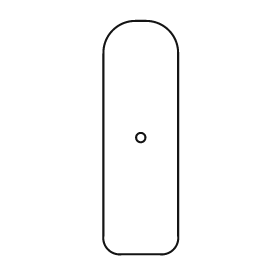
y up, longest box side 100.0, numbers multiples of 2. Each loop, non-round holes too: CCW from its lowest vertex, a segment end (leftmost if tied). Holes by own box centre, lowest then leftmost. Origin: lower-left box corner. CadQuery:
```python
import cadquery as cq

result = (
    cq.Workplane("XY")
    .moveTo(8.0, 0.0)
    .lineTo(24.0, 0.0)
    .threePointArc((30.0, 2.0), (32.0, 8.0))
    .lineTo(32.0, 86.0)
    .threePointArc((28.0, 96.0), (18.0, 100.0))
    .lineTo(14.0, 100.0)
    .threePointArc((4.0, 96.0), (0.0, 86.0))
    .lineTo(0.0, 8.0)
    .threePointArc((2.0, 2.0), (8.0, 0.0))
    .close()
    .moveTo(16.0, 50.0)
    .circle(2.0)
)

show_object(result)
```